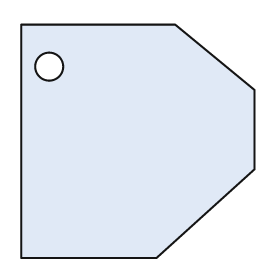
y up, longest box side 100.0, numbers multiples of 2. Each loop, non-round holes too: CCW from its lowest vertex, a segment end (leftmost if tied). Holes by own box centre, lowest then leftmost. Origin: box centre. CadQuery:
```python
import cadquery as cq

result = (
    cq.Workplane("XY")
    .moveTo(-50.0, -50.0)
    .lineTo(8.0, -50.0)
    .lineTo(50.0, -12.0)
    .lineTo(50.0, 22.0)
    .lineTo(16.0, 50.0)
    .lineTo(-50.0, 50.0)
    .close()
    .moveTo(-38.0, 32.0)
    .circle(6.0)
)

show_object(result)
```